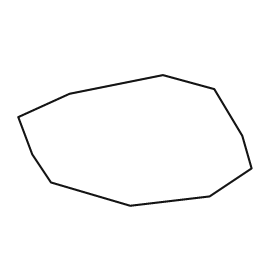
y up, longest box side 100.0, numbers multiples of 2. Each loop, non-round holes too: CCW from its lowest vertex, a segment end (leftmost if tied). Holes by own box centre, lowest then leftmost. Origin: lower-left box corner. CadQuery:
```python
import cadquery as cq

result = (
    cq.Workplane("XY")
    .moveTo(48.0, 0.0)
    .lineTo(82.0, 4.0)
    .lineTo(100.0, 16.0)
    .lineTo(96.0, 30.0)
    .lineTo(84.0, 50.0)
    .lineTo(62.0, 56.0)
    .lineTo(22.0, 48.0)
    .lineTo(0.0, 38.0)
    .lineTo(6.0, 22.0)
    .lineTo(14.0, 10.0)
    .close()
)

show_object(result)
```